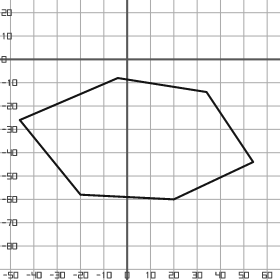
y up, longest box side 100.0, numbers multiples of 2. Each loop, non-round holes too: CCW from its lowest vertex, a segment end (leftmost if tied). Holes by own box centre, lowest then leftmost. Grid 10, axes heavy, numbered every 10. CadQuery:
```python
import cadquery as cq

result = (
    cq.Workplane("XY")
    .moveTo(20.0, -60.0)
    .lineTo(54.0, -44.0)
    .lineTo(34.0, -14.0)
    .lineTo(-4.0, -8.0)
    .lineTo(-46.0, -26.0)
    .lineTo(-20.0, -58.0)
    .close()
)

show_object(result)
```